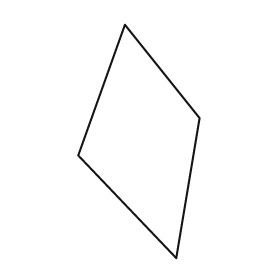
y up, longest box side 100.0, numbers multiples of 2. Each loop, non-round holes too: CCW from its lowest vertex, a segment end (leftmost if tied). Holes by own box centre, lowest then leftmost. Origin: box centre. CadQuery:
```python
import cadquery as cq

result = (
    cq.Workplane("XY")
    .moveTo(16.0, -50.0)
    .lineTo(26.0, 10.0)
    .lineTo(-6.0, 50.0)
    .lineTo(-26.0, -6.0)
    .close()
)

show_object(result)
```